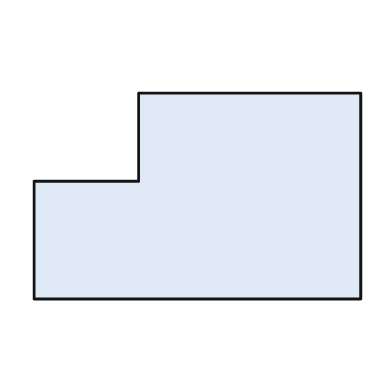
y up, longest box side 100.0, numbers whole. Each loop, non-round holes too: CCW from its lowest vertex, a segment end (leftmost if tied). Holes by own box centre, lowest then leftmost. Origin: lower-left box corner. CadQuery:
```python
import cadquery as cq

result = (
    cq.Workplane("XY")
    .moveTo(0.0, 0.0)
    .lineTo(100.0, 0.0)
    .lineTo(100.0, 63.0)
    .lineTo(32.0, 63.0)
    .lineTo(32.0, 36.0)
    .lineTo(0.0, 36.0)
    .close()
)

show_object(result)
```